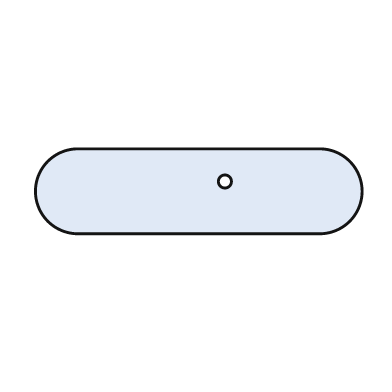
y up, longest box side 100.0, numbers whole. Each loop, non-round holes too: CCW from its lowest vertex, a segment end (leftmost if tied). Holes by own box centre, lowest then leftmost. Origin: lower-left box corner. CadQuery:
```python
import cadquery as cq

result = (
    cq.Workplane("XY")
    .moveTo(13.0, 0.0)
    .lineTo(87.0, 0.0)
    .threePointArc((100.0, 13.0), (87.0, 26.0))
    .lineTo(13.0, 26.0)
    .threePointArc((0.0, 13.0), (13.0, 0.0))
    .close()
    .moveTo(58.0, 16.0)
    .circle(2.0)
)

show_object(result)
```